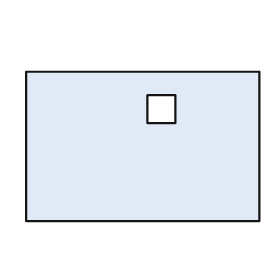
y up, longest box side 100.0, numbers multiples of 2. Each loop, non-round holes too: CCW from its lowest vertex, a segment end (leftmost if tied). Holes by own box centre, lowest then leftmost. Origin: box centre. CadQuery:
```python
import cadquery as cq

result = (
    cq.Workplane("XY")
    .moveTo(-50.0, -32.0)
    .lineTo(50.0, -32.0)
    .lineTo(50.0, 32.0)
    .lineTo(-50.0, 32.0)
    .close()
    .moveTo(2.0, 10.0)
    .lineTo(14.0, 10.0)
    .lineTo(14.0, 22.0)
    .lineTo(2.0, 22.0)
    .close()
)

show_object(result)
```